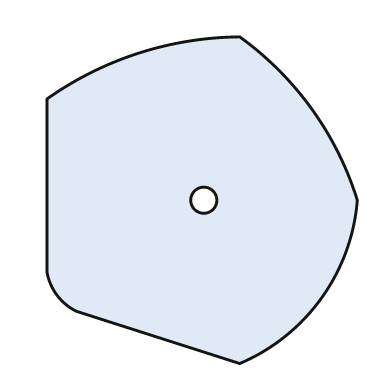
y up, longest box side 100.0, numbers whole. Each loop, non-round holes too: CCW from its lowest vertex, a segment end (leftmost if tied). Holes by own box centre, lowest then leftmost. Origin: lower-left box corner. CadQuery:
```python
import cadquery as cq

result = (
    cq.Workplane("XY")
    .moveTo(59.0, 0.0)
    .threePointArc((84.0, 20.0), (95.0, 50.0))
    .threePointArc((81.0, 78.0), (59.0, 100.0))
    .threePointArc((28.0, 95.0), (0.0, 81.0))
    .lineTo(0.0, 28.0)
    .threePointArc((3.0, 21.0), (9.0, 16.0))
    .close()
    .moveTo(48.0, 50.0)
    .circle(4.0)
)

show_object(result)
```